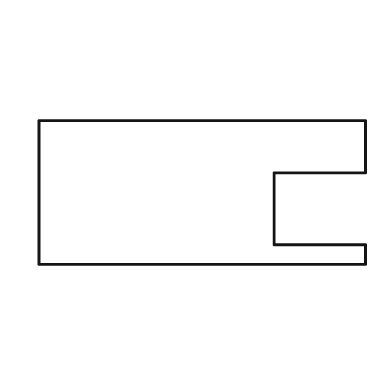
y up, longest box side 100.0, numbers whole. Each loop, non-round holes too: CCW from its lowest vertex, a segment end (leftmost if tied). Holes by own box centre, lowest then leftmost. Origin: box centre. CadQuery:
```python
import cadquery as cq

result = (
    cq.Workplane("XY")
    .moveTo(-50.0, -22.0)
    .lineTo(50.0, -22.0)
    .lineTo(50.0, -16.0)
    .lineTo(22.0, -16.0)
    .lineTo(22.0, 6.0)
    .lineTo(50.0, 6.0)
    .lineTo(50.0, 22.0)
    .lineTo(-50.0, 22.0)
    .close()
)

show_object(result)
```